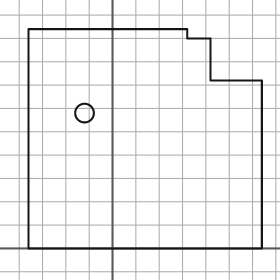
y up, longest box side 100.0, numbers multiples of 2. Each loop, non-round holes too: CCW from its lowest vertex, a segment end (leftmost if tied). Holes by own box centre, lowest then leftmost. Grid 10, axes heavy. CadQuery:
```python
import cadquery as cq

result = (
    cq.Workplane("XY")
    .moveTo(-36.0, 0.0)
    .lineTo(64.0, 0.0)
    .lineTo(64.0, 72.0)
    .lineTo(42.0, 72.0)
    .lineTo(42.0, 90.0)
    .lineTo(32.0, 90.0)
    .lineTo(32.0, 94.0)
    .lineTo(-36.0, 94.0)
    .close()
    .moveTo(-12.0, 58.0)
    .circle(4.0)
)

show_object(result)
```